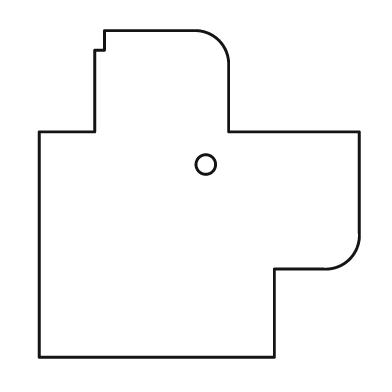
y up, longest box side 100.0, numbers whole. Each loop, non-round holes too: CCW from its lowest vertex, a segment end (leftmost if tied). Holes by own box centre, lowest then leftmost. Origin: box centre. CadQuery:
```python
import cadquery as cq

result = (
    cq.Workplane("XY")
    .moveTo(-49.0, -50.0)
    .lineTo(23.0, -50.0)
    .lineTo(23.0, -23.0)
    .lineTo(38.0, -23.0)
    .threePointArc((46.0, -20.0), (49.0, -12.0))
    .lineTo(49.0, 19.0)
    .lineTo(9.0, 19.0)
    .lineTo(9.0, 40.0)
    .threePointArc((6.0, 47.0), (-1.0, 50.0))
    .lineTo(-29.0, 50.0)
    .lineTo(-29.0, 44.0)
    .lineTo(-32.0, 44.0)
    .lineTo(-32.0, 19.0)
    .lineTo(-49.0, 19.0)
    .close()
    .moveTo(2.0, 9.0)
    .circle(3.0)
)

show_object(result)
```